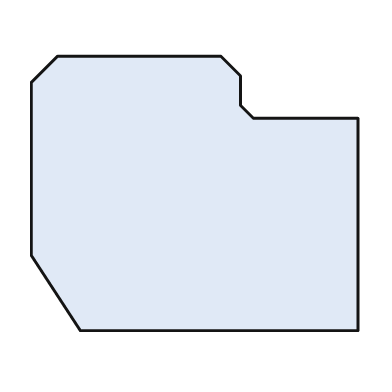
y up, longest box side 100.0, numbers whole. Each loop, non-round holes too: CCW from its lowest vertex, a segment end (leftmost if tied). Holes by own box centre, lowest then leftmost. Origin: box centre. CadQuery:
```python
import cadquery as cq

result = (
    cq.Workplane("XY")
    .moveTo(-35.0, -42.0)
    .lineTo(50.0, -42.0)
    .lineTo(50.0, 23.0)
    .lineTo(18.0, 23.0)
    .lineTo(14.0, 27.0)
    .lineTo(14.0, 36.0)
    .lineTo(8.0, 42.0)
    .lineTo(-42.0, 42.0)
    .lineTo(-50.0, 34.0)
    .lineTo(-50.0, -19.0)
    .close()
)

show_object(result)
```